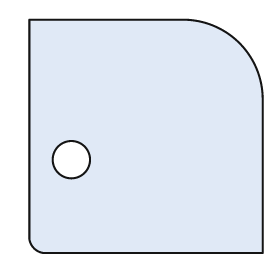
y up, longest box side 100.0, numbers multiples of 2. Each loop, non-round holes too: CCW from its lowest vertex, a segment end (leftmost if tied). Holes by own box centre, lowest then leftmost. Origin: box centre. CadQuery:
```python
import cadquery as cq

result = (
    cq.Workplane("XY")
    .moveTo(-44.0, -50.0)
    .lineTo(50.0, -50.0)
    .lineTo(50.0, 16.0)
    .threePointArc((40.0, 40.0), (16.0, 50.0))
    .lineTo(-50.0, 50.0)
    .lineTo(-50.0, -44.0)
    .threePointArc((-48.0, -48.0), (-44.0, -50.0))
    .close()
    .moveTo(-32.0, -10.0)
    .circle(8.0)
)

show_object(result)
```